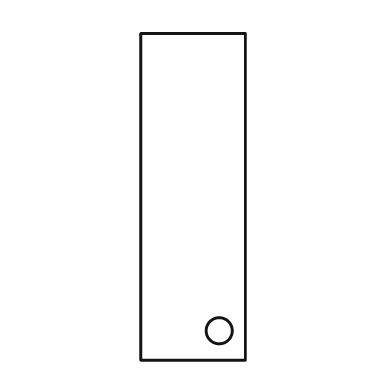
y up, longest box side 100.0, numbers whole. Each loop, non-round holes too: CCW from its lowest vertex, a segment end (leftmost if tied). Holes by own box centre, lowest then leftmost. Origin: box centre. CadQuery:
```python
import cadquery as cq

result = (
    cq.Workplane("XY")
    .moveTo(-16.0, -50.0)
    .lineTo(16.0, -50.0)
    .lineTo(16.0, 50.0)
    .lineTo(-16.0, 50.0)
    .close()
    .moveTo(8.0, -41.0)
    .circle(4.0)
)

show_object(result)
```